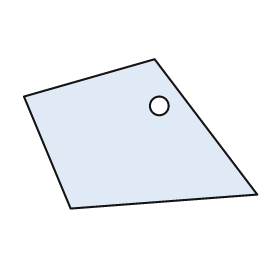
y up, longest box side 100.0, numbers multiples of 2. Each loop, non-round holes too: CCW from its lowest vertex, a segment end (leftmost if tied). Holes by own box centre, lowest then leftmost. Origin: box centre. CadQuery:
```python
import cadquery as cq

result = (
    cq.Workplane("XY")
    .moveTo(-30.0, -32.0)
    .lineTo(50.0, -26.0)
    .lineTo(6.0, 32.0)
    .lineTo(-50.0, 16.0)
    .close()
    .moveTo(8.0, 12.0)
    .circle(4.0)
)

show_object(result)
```